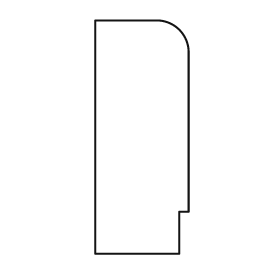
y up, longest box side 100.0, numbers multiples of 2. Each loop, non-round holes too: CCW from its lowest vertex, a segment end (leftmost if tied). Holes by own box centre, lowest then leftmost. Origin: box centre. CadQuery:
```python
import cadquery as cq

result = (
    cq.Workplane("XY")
    .moveTo(-20.0, -50.0)
    .lineTo(16.0, -50.0)
    .lineTo(16.0, -32.0)
    .lineTo(20.0, -32.0)
    .lineTo(20.0, 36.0)
    .threePointArc((16.0, 46.0), (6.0, 50.0))
    .lineTo(-20.0, 50.0)
    .close()
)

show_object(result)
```